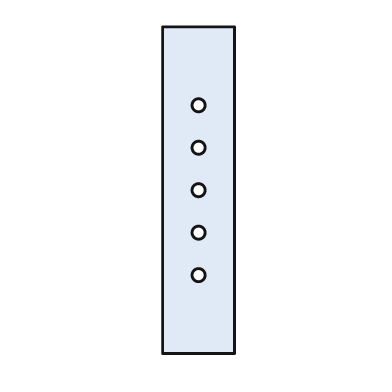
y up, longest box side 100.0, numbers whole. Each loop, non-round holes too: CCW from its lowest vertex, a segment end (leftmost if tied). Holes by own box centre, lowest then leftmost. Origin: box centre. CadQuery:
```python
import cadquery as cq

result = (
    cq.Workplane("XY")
    .moveTo(-11.0, -50.0)
    .lineTo(11.0, -50.0)
    .lineTo(11.0, 50.0)
    .lineTo(-11.0, 50.0)
    .close()
    .moveTo(0.0, -26.0)
    .circle(2.0)
    .moveTo(0.0, -13.0)
    .circle(2.0)
    .moveTo(0.0, 0.0)
    .circle(2.0)
    .moveTo(0.0, 13.0)
    .circle(2.0)
    .moveTo(0.0, 26.0)
    .circle(2.0)
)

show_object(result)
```